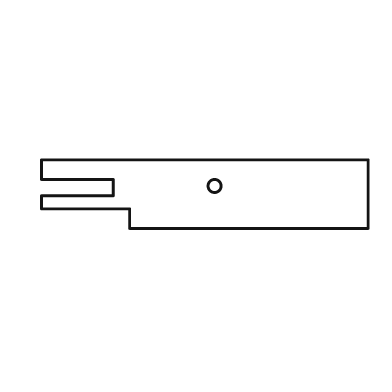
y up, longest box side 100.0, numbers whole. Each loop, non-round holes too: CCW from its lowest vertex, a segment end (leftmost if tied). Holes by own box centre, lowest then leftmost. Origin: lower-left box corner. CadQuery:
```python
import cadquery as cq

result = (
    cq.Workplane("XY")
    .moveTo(27.0, 0.0)
    .lineTo(100.0, 0.0)
    .lineTo(100.0, 21.0)
    .lineTo(0.0, 21.0)
    .lineTo(0.0, 15.0)
    .lineTo(22.0, 15.0)
    .lineTo(22.0, 10.0)
    .lineTo(0.0, 10.0)
    .lineTo(0.0, 6.0)
    .lineTo(27.0, 6.0)
    .close()
    .moveTo(53.0, 13.0)
    .circle(2.0)
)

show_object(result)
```